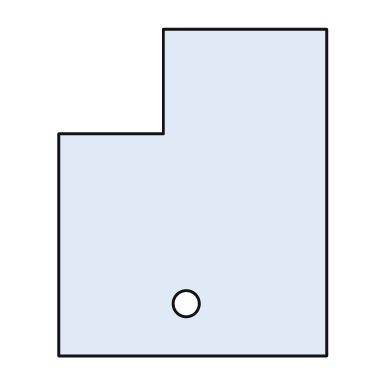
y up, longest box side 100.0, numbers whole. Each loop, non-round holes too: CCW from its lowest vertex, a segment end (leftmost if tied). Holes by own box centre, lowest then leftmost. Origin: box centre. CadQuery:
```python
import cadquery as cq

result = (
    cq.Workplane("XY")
    .moveTo(-41.0, -50.0)
    .lineTo(41.0, -50.0)
    .lineTo(41.0, 50.0)
    .lineTo(-9.0, 50.0)
    .lineTo(-9.0, 18.0)
    .lineTo(-41.0, 18.0)
    .close()
    .moveTo(-2.0, -34.0)
    .circle(4.0)
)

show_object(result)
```